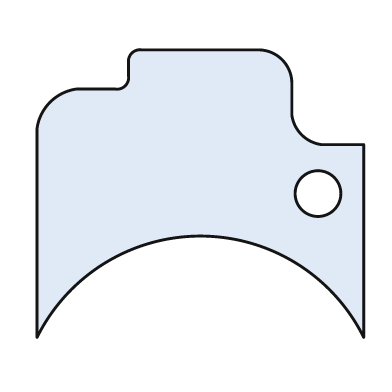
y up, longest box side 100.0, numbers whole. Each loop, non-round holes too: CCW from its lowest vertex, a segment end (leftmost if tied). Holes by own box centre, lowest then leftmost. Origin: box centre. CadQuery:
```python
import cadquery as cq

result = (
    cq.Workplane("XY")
    .moveTo(-50.0, -44.0)
    .threePointArc((0.0, -13.0), (50.0, -44.0))
    .lineTo(50.0, 15.0)
    .lineTo(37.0, 15.0)
    .threePointArc((31.0, 18.0), (28.0, 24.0))
    .lineTo(28.0, 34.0)
    .threePointArc((25.0, 41.0), (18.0, 44.0))
    .lineTo(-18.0, 44.0)
    .threePointArc((-21.0, 43.0), (-22.0, 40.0))
    .lineTo(-22.0, 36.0)
    .threePointArc((-23.0, 33.0), (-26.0, 32.0))
    .lineTo(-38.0, 32.0)
    .threePointArc((-46.0, 28.0), (-50.0, 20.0))
    .close()
    .moveTo(36.0, 0.0)
    .circle(7.0)
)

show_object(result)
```